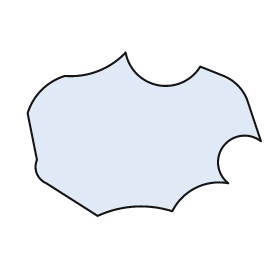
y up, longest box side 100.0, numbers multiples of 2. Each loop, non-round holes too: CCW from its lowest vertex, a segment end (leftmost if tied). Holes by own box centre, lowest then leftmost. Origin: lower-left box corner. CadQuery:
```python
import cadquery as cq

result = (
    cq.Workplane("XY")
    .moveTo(30.0, 0.0)
    .threePointArc((46.0, 4.0), (62.0, 2.0))
    .threePointArc((72.0, 12.0), (86.0, 14.0))
    .threePointArc((84.0, 30.0), (100.0, 32.0))
    .lineTo(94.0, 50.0)
    .threePointArc((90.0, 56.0), (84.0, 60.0))
    .lineTo(74.0, 64.0)
    .threePointArc((56.0, 56.0), (42.0, 70.0))
    .threePointArc((30.0, 62.0), (16.0, 60.0))
    .threePointArc((6.0, 54.0), (0.0, 44.0))
    .lineTo(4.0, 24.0)
    .threePointArc((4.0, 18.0), (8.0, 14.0))
    .close()
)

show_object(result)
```